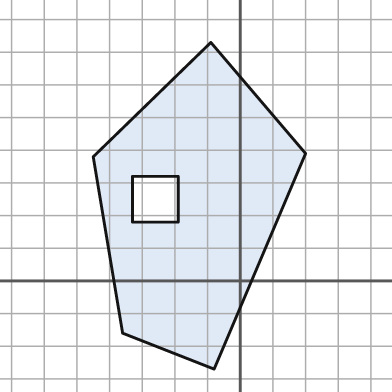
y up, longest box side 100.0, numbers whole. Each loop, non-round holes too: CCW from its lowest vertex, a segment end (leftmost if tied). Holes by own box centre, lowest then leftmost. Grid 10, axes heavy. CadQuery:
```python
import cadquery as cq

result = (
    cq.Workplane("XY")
    .moveTo(-8.0, -27.0)
    .lineTo(20.0, 39.0)
    .lineTo(-9.0, 73.0)
    .lineTo(-45.0, 38.0)
    .lineTo(-36.0, -16.0)
    .close()
    .moveTo(-33.0, 18.0)
    .lineTo(-19.0, 18.0)
    .lineTo(-19.0, 32.0)
    .lineTo(-33.0, 32.0)
    .close()
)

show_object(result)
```